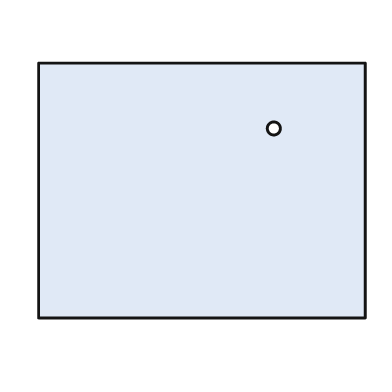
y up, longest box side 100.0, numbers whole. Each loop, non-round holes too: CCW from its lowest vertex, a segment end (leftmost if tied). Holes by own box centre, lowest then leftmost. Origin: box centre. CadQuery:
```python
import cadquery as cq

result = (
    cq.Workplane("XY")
    .moveTo(-50.0, -39.0)
    .lineTo(50.0, -39.0)
    .lineTo(50.0, 39.0)
    .lineTo(-50.0, 39.0)
    .close()
    .moveTo(22.0, 19.0)
    .circle(2.0)
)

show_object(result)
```